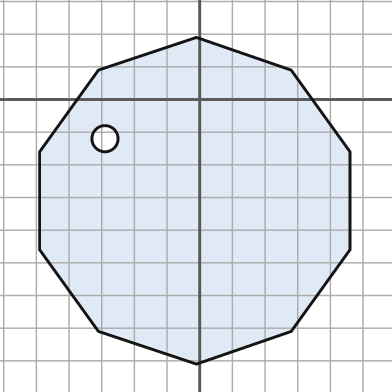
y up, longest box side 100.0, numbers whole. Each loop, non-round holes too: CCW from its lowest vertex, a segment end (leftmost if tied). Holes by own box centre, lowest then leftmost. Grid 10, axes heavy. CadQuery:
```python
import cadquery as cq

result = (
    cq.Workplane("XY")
    .moveTo(-1.0, -81.0)
    .lineTo(28.0, -71.0)
    .lineTo(46.0, -46.0)
    .lineTo(46.0, -16.0)
    .lineTo(28.0, 9.0)
    .lineTo(-1.0, 19.0)
    .lineTo(-31.0, 9.0)
    .lineTo(-49.0, -16.0)
    .lineTo(-49.0, -46.0)
    .lineTo(-31.0, -71.0)
    .close()
    .moveTo(-29.0, -12.0)
    .circle(4.0)
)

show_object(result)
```